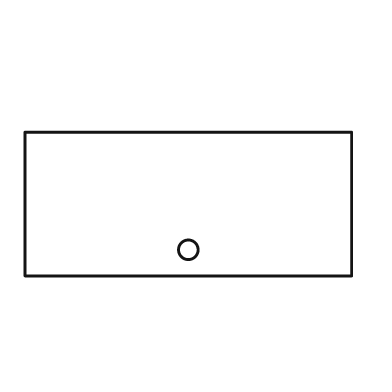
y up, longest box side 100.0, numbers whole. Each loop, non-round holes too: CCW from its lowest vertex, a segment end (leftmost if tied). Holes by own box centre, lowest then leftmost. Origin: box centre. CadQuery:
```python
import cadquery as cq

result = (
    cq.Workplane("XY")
    .moveTo(-50.0, -22.0)
    .lineTo(50.0, -22.0)
    .lineTo(50.0, 22.0)
    .lineTo(-50.0, 22.0)
    .close()
    .moveTo(0.0, -14.0)
    .circle(3.0)
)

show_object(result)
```